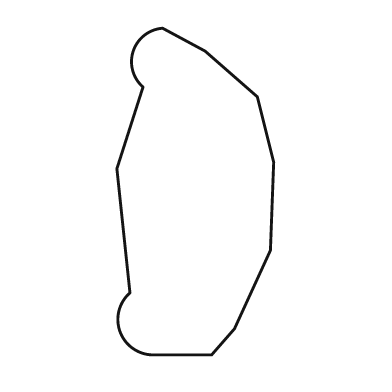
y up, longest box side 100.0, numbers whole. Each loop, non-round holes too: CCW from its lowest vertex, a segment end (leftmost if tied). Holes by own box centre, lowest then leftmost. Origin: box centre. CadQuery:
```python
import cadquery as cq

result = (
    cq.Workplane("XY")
    .moveTo(-13.0, -50.0)
    .lineTo(5.0, -50.0)
    .lineTo(12.0, -42.0)
    .lineTo(23.0, -18.0)
    .lineTo(24.0, 9.0)
    .lineTo(19.0, 29.0)
    .lineTo(3.0, 43.0)
    .lineTo(-10.0, 50.0)
    .threePointArc((-19.0, 43.0), (-16.0, 32.0))
    .lineTo(-24.0, 7.0)
    .lineTo(-20.0, -31.0)
    .threePointArc((-23.0, -43.0), (-13.0, -50.0))
    .close()
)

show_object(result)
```